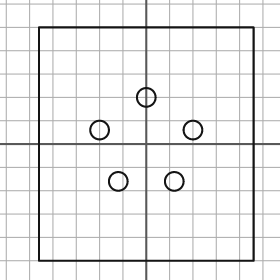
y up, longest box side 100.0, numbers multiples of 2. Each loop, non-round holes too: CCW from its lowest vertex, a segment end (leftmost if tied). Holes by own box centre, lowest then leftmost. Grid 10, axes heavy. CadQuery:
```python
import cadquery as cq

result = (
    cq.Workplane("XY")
    .moveTo(-46.0, -50.0)
    .lineTo(46.0, -50.0)
    .lineTo(46.0, 50.0)
    .lineTo(-46.0, 50.0)
    .close()
    .moveTo(-12.0, -16.0)
    .circle(4.0)
    .moveTo(12.0, -16.0)
    .circle(4.0)
    .moveTo(-20.0, 6.0)
    .circle(4.0)
    .moveTo(20.0, 6.0)
    .circle(4.0)
    .moveTo(0.0, 20.0)
    .circle(4.0)
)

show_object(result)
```